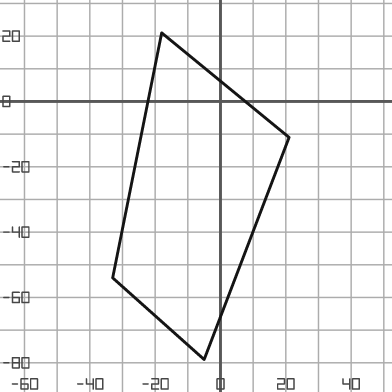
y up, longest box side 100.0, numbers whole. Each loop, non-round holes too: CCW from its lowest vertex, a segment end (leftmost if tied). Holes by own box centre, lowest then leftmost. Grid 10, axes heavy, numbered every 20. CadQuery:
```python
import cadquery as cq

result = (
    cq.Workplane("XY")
    .moveTo(-5.0, -79.0)
    .lineTo(21.0, -11.0)
    .lineTo(-18.0, 21.0)
    .lineTo(-33.0, -54.0)
    .close()
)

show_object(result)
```